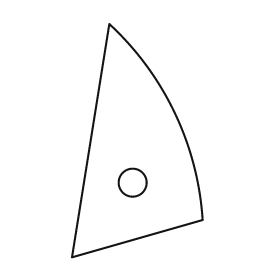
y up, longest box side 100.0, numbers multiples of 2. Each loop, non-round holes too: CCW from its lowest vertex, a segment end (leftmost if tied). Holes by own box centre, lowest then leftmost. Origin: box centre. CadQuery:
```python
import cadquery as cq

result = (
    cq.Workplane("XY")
    .moveTo(-28.0, -50.0)
    .lineTo(28.0, -34.0)
    .threePointArc((16.0, 12.0), (-12.0, 50.0))
    .close()
    .moveTo(-2.0, -18.0)
    .circle(6.0)
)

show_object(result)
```